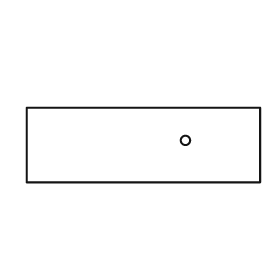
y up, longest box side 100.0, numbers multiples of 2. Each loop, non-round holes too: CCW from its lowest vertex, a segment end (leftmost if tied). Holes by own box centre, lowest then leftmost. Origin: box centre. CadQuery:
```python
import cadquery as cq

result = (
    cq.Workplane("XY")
    .moveTo(-50.0, -16.0)
    .lineTo(50.0, -16.0)
    .lineTo(50.0, 16.0)
    .lineTo(-50.0, 16.0)
    .close()
    .moveTo(18.0, 2.0)
    .circle(2.0)
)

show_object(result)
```